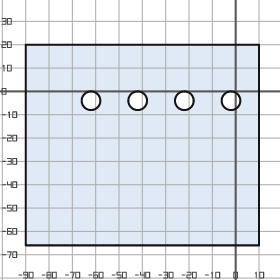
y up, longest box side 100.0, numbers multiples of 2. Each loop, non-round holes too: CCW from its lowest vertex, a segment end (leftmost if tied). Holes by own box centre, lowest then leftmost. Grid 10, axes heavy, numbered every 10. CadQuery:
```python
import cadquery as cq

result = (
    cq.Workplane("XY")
    .moveTo(-90.0, -66.0)
    .lineTo(10.0, -66.0)
    .lineTo(10.0, 20.0)
    .lineTo(-90.0, 20.0)
    .close()
    .moveTo(-62.0, -4.0)
    .circle(4.0)
    .moveTo(-42.0, -4.0)
    .circle(4.0)
    .moveTo(-22.0, -4.0)
    .circle(4.0)
    .moveTo(-2.0, -4.0)
    .circle(4.0)
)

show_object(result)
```